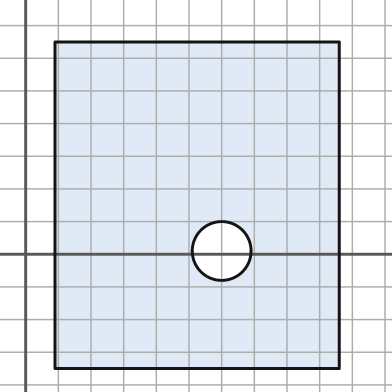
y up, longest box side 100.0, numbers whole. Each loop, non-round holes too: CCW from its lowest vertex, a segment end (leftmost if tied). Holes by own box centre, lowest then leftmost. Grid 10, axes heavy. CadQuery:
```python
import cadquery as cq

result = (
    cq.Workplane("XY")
    .moveTo(9.0, -35.0)
    .lineTo(96.0, -35.0)
    .lineTo(96.0, 65.0)
    .lineTo(9.0, 65.0)
    .close()
    .moveTo(60.0, 1.0)
    .circle(9.0)
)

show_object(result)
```